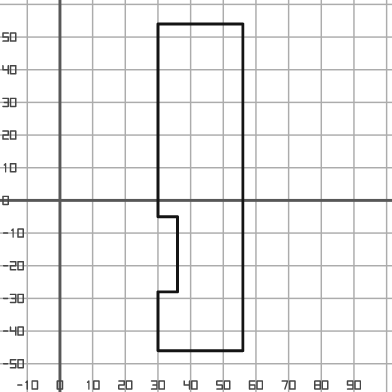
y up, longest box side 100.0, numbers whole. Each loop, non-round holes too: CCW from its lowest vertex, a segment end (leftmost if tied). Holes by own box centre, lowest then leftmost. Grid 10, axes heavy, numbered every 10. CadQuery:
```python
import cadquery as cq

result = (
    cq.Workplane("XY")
    .moveTo(30.0, -46.0)
    .lineTo(56.0, -46.0)
    .lineTo(56.0, 54.0)
    .lineTo(30.0, 54.0)
    .lineTo(30.0, -5.0)
    .lineTo(36.0, -5.0)
    .lineTo(36.0, -28.0)
    .lineTo(30.0, -28.0)
    .close()
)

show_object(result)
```